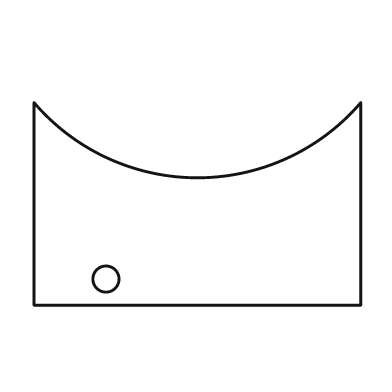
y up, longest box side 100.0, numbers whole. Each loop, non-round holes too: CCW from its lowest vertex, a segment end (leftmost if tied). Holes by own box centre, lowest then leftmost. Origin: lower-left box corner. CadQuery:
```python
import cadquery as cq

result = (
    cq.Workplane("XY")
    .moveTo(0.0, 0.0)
    .lineTo(100.0, 0.0)
    .lineTo(100.0, 62.0)
    .threePointArc((50.0, 39.0), (0.0, 62.0))
    .close()
    .moveTo(22.0, 8.0)
    .circle(4.0)
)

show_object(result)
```